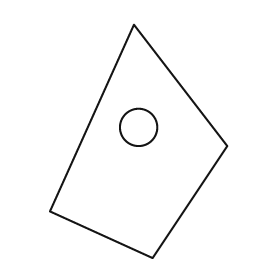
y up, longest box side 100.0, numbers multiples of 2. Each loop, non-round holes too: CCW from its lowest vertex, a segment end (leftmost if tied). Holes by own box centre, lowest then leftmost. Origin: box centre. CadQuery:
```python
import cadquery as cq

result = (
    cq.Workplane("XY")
    .moveTo(6.0, -50.0)
    .lineTo(38.0, -2.0)
    .lineTo(-2.0, 50.0)
    .lineTo(-38.0, -30.0)
    .close()
    .moveTo(0.0, 6.0)
    .circle(8.0)
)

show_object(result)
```